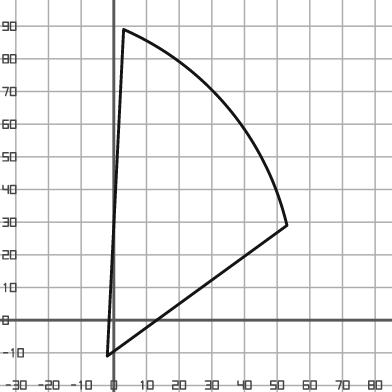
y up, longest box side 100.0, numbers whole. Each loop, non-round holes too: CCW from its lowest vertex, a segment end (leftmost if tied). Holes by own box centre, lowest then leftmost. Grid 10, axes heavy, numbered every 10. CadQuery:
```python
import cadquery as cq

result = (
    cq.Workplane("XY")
    .moveTo(-2.0, -11.0)
    .lineTo(53.0, 29.0)
    .threePointArc((35.0, 65.0), (3.0, 89.0))
    .close()
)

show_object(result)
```